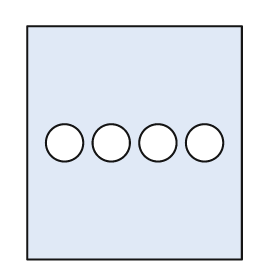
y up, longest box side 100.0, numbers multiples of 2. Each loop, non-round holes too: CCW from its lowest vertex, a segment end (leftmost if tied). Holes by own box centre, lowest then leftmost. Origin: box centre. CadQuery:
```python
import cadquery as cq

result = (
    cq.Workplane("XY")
    .moveTo(-46.0, -50.0)
    .lineTo(46.0, -50.0)
    .lineTo(46.0, 50.0)
    .lineTo(-46.0, 50.0)
    .close()
    .moveTo(-30.0, 0.0)
    .circle(8.0)
    .moveTo(-10.0, 0.0)
    .circle(8.0)
    .moveTo(10.0, 0.0)
    .circle(8.0)
    .moveTo(30.0, 0.0)
    .circle(8.0)
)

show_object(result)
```